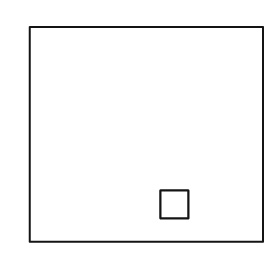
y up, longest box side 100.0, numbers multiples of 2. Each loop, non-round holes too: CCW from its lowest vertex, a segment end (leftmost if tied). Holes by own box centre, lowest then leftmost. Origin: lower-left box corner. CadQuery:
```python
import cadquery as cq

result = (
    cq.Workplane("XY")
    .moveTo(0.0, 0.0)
    .lineTo(100.0, 0.0)
    .lineTo(100.0, 92.0)
    .lineTo(0.0, 92.0)
    .close()
    .moveTo(56.0, 10.0)
    .lineTo(68.0, 10.0)
    .lineTo(68.0, 22.0)
    .lineTo(56.0, 22.0)
    .close()
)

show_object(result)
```